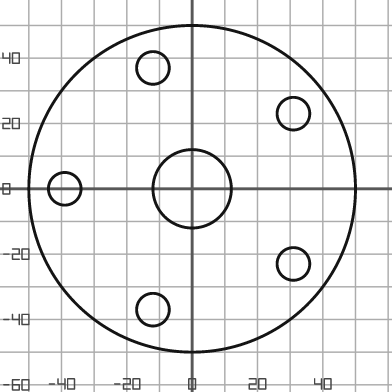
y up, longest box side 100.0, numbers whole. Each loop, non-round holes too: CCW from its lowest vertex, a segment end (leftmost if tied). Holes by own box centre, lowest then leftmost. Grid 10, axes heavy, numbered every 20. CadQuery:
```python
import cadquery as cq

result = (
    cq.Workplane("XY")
    .moveTo(0.0, 0.0)
    .circle(50.0)
    .moveTo(-12.0, -37.0)
    .circle(5.0)
    .moveTo(31.0, -23.0)
    .circle(5.0)
    .moveTo(-39.0, 0.0)
    .circle(5.0)
    .moveTo(0.0, 0.0)
    .circle(12.0)
    .moveTo(31.0, 23.0)
    .circle(5.0)
    .moveTo(-12.0, 37.0)
    .circle(5.0)
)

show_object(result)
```